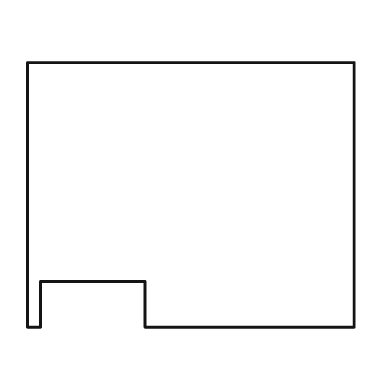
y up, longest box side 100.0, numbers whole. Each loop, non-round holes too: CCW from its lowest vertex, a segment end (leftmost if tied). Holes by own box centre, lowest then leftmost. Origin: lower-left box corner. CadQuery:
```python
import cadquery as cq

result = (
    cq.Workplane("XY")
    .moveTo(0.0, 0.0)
    .lineTo(4.0, 0.0)
    .lineTo(4.0, 14.0)
    .lineTo(36.0, 14.0)
    .lineTo(36.0, 0.0)
    .lineTo(100.0, 0.0)
    .lineTo(100.0, 81.0)
    .lineTo(0.0, 81.0)
    .close()
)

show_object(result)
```